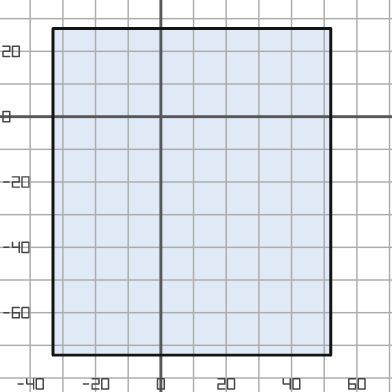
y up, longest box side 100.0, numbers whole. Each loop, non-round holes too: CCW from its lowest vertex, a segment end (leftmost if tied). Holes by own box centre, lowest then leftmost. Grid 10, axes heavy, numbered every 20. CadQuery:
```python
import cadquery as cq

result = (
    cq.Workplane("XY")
    .moveTo(-33.0, -73.0)
    .lineTo(52.0, -73.0)
    .lineTo(52.0, 27.0)
    .lineTo(-33.0, 27.0)
    .close()
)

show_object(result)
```